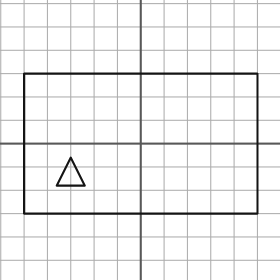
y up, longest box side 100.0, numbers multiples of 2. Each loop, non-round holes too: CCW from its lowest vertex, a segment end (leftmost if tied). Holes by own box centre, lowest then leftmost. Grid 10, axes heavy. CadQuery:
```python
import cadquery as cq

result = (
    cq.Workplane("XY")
    .moveTo(-50.0, -30.0)
    .lineTo(50.0, -30.0)
    .lineTo(50.0, 30.0)
    .lineTo(-50.0, 30.0)
    .close()
    .moveTo(-36.0, -18.0)
    .lineTo(-24.0, -18.0)
    .lineTo(-30.0, -6.0)
    .close()
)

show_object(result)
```